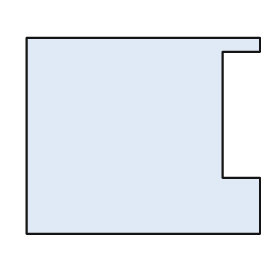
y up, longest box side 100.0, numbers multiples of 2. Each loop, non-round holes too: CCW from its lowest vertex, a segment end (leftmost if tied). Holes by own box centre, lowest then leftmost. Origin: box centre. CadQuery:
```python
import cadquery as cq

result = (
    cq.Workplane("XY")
    .moveTo(-50.0, -42.0)
    .lineTo(50.0, -42.0)
    .lineTo(50.0, -18.0)
    .lineTo(34.0, -18.0)
    .lineTo(34.0, 36.0)
    .lineTo(50.0, 36.0)
    .lineTo(50.0, 42.0)
    .lineTo(-50.0, 42.0)
    .close()
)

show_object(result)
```